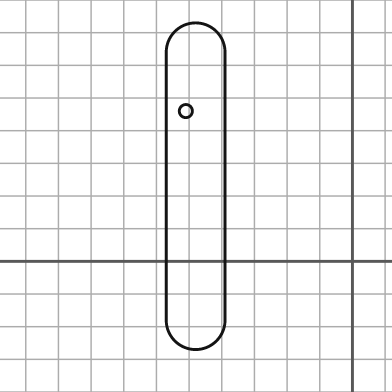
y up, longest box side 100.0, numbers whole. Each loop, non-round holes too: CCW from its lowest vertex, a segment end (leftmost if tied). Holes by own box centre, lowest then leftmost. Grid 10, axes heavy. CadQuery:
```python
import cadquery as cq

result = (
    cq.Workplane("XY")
    .moveTo(-57.0, -18.0)
    .threePointArc((-48.0, -27.0), (-39.0, -18.0))
    .lineTo(-39.0, 64.0)
    .threePointArc((-48.0, 73.0), (-57.0, 64.0))
    .close()
    .moveTo(-51.0, 46.0)
    .circle(2.0)
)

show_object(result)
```